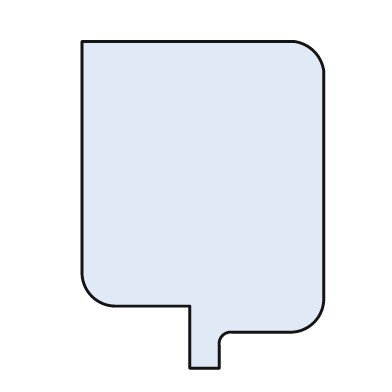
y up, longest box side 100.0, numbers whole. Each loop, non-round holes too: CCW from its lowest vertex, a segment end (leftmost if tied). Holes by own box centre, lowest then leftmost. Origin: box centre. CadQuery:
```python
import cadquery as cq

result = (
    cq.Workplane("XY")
    .moveTo(-4.0, -50.0)
    .lineTo(5.0, -50.0)
    .lineTo(5.0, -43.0)
    .threePointArc((6.0, -40.0), (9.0, -39.0))
    .lineTo(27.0, -39.0)
    .threePointArc((34.0, -36.0), (37.0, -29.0))
    .lineTo(37.0, 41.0)
    .threePointArc((34.0, 47.0), (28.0, 50.0))
    .lineTo(-37.0, 50.0)
    .lineTo(-37.0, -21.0)
    .threePointArc((-34.0, -28.0), (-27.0, -31.0))
    .lineTo(-4.0, -31.0)
    .close()
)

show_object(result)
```